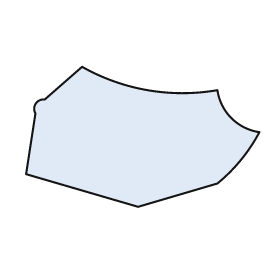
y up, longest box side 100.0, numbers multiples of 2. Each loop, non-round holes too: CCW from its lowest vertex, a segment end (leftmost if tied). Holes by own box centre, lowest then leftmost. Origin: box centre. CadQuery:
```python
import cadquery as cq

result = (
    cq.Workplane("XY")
    .moveTo(-2.0, -30.0)
    .lineTo(32.0, -20.0)
    .threePointArc((42.0, -10.0), (50.0, 2.0))
    .threePointArc((38.0, 8.0), (32.0, 20.0))
    .threePointArc((2.0, 20.0), (-26.0, 30.0))
    .lineTo(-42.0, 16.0)
    .threePointArc((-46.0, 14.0), (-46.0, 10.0))
    .lineTo(-50.0, -16.0)
    .close()
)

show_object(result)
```